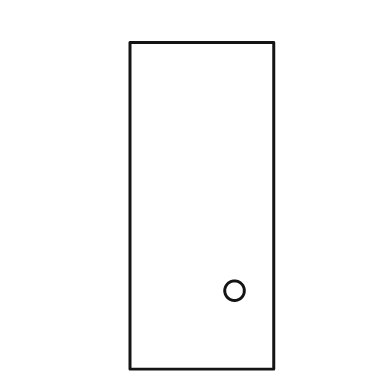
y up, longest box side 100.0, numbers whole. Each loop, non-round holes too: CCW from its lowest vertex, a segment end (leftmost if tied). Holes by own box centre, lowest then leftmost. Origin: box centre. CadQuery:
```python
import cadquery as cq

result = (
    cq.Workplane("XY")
    .moveTo(-22.0, -50.0)
    .lineTo(22.0, -50.0)
    .lineTo(22.0, 50.0)
    .lineTo(-22.0, 50.0)
    .close()
    .moveTo(10.0, -26.0)
    .circle(3.0)
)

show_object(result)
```